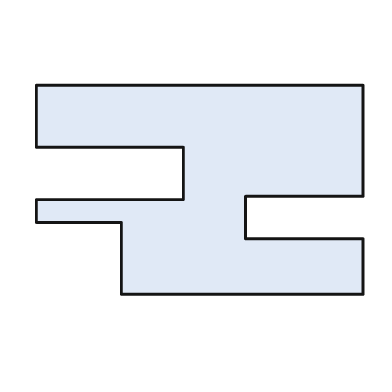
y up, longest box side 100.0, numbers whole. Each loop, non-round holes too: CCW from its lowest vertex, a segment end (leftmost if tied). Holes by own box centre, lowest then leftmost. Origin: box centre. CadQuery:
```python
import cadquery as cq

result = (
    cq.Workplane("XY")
    .moveTo(-24.0, -32.0)
    .lineTo(50.0, -32.0)
    .lineTo(50.0, -15.0)
    .lineTo(14.0, -15.0)
    .lineTo(14.0, -2.0)
    .lineTo(50.0, -2.0)
    .lineTo(50.0, 32.0)
    .lineTo(-50.0, 32.0)
    .lineTo(-50.0, 13.0)
    .lineTo(-5.0, 13.0)
    .lineTo(-5.0, -3.0)
    .lineTo(-50.0, -3.0)
    .lineTo(-50.0, -10.0)
    .lineTo(-24.0, -10.0)
    .close()
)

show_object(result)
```